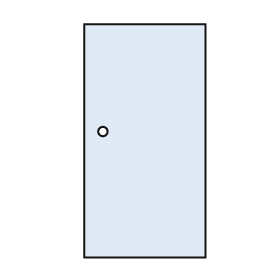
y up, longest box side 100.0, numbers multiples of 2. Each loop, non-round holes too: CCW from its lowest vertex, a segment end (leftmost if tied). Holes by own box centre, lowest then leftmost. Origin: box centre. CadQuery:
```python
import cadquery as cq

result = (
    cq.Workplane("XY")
    .moveTo(-26.0, -50.0)
    .lineTo(26.0, -50.0)
    .lineTo(26.0, 50.0)
    .lineTo(-26.0, 50.0)
    .close()
    .moveTo(-18.0, 4.0)
    .circle(2.0)
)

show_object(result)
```